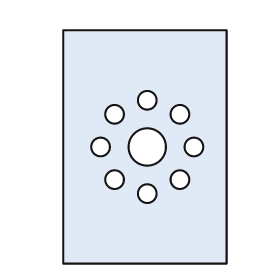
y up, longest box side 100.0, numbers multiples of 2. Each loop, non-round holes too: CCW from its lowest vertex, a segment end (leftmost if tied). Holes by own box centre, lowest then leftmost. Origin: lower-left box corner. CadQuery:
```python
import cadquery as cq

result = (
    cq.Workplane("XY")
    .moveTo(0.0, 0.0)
    .lineTo(70.0, 0.0)
    .lineTo(70.0, 100.0)
    .lineTo(0.0, 100.0)
    .close()
    .moveTo(36.0, 30.0)
    .circle(4.0)
    .moveTo(22.0, 36.0)
    .circle(4.0)
    .moveTo(50.0, 36.0)
    .circle(4.0)
    .moveTo(16.0, 50.0)
    .circle(4.0)
    .moveTo(36.0, 50.0)
    .circle(8.0)
    .moveTo(56.0, 50.0)
    .circle(4.0)
    .moveTo(22.0, 64.0)
    .circle(4.0)
    .moveTo(50.0, 64.0)
    .circle(4.0)
    .moveTo(36.0, 70.0)
    .circle(4.0)
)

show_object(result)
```